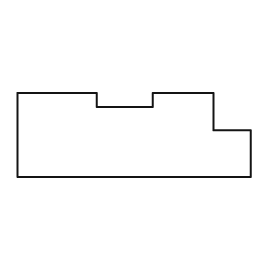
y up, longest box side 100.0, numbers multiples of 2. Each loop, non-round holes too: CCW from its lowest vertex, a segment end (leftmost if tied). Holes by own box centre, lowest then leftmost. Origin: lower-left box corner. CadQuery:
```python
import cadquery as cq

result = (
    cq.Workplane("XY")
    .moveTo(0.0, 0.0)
    .lineTo(100.0, 0.0)
    .lineTo(100.0, 20.0)
    .lineTo(84.0, 20.0)
    .lineTo(84.0, 36.0)
    .lineTo(58.0, 36.0)
    .lineTo(58.0, 30.0)
    .lineTo(34.0, 30.0)
    .lineTo(34.0, 36.0)
    .lineTo(0.0, 36.0)
    .close()
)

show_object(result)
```